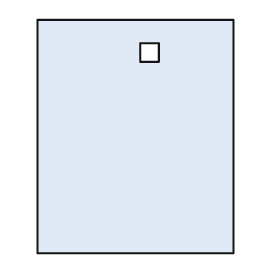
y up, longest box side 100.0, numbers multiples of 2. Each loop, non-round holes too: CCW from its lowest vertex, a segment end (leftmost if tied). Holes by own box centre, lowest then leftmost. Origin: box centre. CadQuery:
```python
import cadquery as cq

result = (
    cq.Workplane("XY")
    .moveTo(-42.0, -50.0)
    .lineTo(42.0, -50.0)
    .lineTo(42.0, 50.0)
    .lineTo(-42.0, 50.0)
    .close()
    .moveTo(2.0, 32.0)
    .lineTo(10.0, 32.0)
    .lineTo(10.0, 40.0)
    .lineTo(2.0, 40.0)
    .close()
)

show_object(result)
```